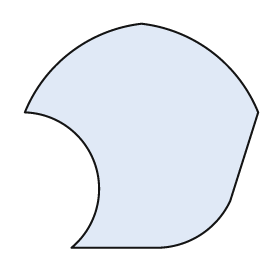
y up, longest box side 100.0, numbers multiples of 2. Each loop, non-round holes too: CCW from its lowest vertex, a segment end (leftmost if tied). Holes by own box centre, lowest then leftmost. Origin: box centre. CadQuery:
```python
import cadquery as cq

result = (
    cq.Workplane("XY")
    .moveTo(-30.0, -48.0)
    .lineTo(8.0, -48.0)
    .threePointArc((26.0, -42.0), (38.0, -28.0))
    .lineTo(50.0, 10.0)
    .threePointArc((30.0, 36.0), (0.0, 48.0))
    .threePointArc((-30.0, 36.0), (-50.0, 10.0))
    .threePointArc((-20.0, -12.0), (-30.0, -48.0))
    .close()
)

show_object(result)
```